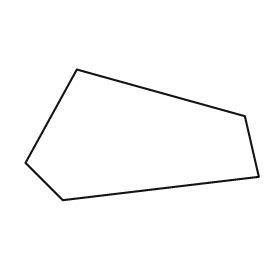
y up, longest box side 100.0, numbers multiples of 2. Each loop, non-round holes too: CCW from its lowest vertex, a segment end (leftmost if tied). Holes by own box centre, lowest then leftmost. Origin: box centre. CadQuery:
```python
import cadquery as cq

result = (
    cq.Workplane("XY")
    .moveTo(-34.0, -28.0)
    .lineTo(50.0, -18.0)
    .lineTo(44.0, 8.0)
    .lineTo(-28.0, 28.0)
    .lineTo(-50.0, -12.0)
    .close()
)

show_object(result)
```